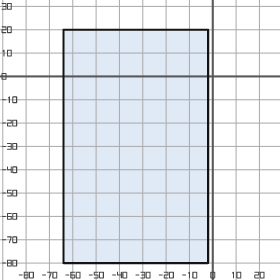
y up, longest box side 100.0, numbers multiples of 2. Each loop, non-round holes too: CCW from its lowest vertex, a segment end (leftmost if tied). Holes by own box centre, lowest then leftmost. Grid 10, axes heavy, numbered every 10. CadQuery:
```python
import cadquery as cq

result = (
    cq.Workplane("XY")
    .moveTo(-64.0, -80.0)
    .lineTo(-2.0, -80.0)
    .lineTo(-2.0, 20.0)
    .lineTo(-64.0, 20.0)
    .close()
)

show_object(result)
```